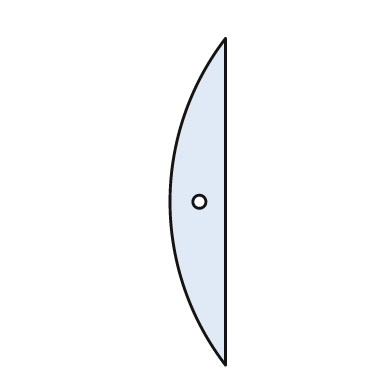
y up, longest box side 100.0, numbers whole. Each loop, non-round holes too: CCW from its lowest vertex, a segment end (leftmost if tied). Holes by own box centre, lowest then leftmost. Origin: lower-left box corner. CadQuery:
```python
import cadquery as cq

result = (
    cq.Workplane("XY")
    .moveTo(17.0, 0.0)
    .lineTo(17.0, 100.0)
    .threePointArc((0.0, 50.0), (17.0, 0.0))
    .close()
    .moveTo(9.0, 50.0)
    .circle(2.0)
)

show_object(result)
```